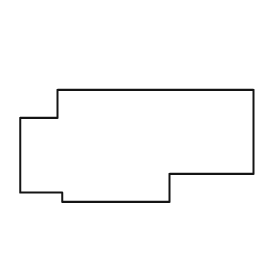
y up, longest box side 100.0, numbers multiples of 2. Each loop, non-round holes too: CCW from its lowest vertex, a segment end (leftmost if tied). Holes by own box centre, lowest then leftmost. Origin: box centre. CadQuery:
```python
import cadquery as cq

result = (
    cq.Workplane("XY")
    .moveTo(-32.0, -24.0)
    .lineTo(14.0, -24.0)
    .lineTo(14.0, -12.0)
    .lineTo(50.0, -12.0)
    .lineTo(50.0, 24.0)
    .lineTo(-34.0, 24.0)
    .lineTo(-34.0, 12.0)
    .lineTo(-50.0, 12.0)
    .lineTo(-50.0, -20.0)
    .lineTo(-32.0, -20.0)
    .close()
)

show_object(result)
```